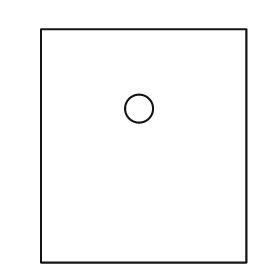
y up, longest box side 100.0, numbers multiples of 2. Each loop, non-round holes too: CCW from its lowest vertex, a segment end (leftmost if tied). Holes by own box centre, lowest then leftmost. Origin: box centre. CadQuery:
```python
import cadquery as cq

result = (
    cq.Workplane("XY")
    .moveTo(-44.0, -50.0)
    .lineTo(44.0, -50.0)
    .lineTo(44.0, 50.0)
    .lineTo(-44.0, 50.0)
    .close()
    .moveTo(-2.0, 16.0)
    .circle(6.0)
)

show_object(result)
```